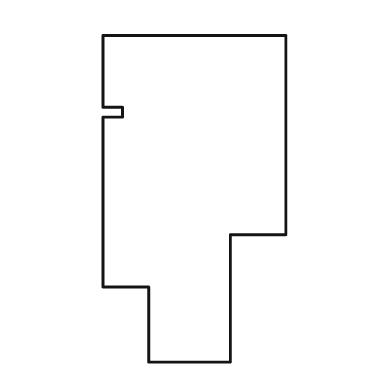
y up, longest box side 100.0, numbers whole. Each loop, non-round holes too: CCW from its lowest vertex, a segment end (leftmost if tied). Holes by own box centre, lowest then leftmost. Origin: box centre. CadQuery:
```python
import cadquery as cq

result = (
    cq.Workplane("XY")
    .moveTo(-14.0, -50.0)
    .lineTo(11.0, -50.0)
    .lineTo(11.0, -11.0)
    .lineTo(28.0, -11.0)
    .lineTo(28.0, 50.0)
    .lineTo(-28.0, 50.0)
    .lineTo(-28.0, 28.0)
    .lineTo(-22.0, 28.0)
    .lineTo(-22.0, 25.0)
    .lineTo(-28.0, 25.0)
    .lineTo(-28.0, -27.0)
    .lineTo(-14.0, -27.0)
    .close()
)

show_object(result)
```